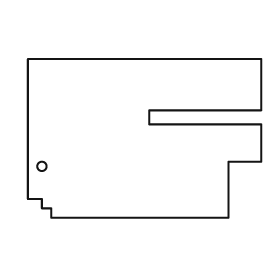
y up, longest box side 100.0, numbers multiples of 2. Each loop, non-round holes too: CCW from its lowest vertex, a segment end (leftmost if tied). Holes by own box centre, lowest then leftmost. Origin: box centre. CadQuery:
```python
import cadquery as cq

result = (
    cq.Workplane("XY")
    .moveTo(-40.0, -34.0)
    .lineTo(36.0, -34.0)
    .lineTo(36.0, -10.0)
    .lineTo(50.0, -10.0)
    .lineTo(50.0, 6.0)
    .lineTo(2.0, 6.0)
    .lineTo(2.0, 12.0)
    .lineTo(50.0, 12.0)
    .lineTo(50.0, 34.0)
    .lineTo(-50.0, 34.0)
    .lineTo(-50.0, -26.0)
    .lineTo(-44.0, -26.0)
    .lineTo(-44.0, -30.0)
    .lineTo(-40.0, -30.0)
    .close()
    .moveTo(-44.0, -12.0)
    .circle(2.0)
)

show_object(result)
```